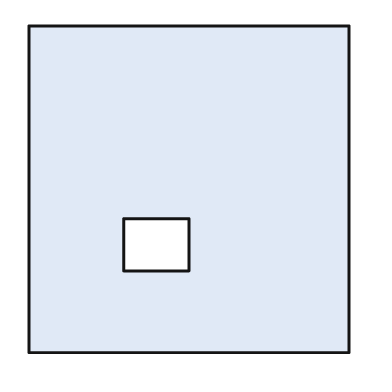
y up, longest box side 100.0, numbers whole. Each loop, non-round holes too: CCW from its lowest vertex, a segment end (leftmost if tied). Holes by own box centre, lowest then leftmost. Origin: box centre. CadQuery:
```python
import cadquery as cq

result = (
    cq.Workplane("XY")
    .moveTo(-49.0, -50.0)
    .lineTo(49.0, -50.0)
    .lineTo(49.0, 50.0)
    .lineTo(-49.0, 50.0)
    .close()
    .moveTo(-20.0, -25.0)
    .lineTo(0.0, -25.0)
    .lineTo(0.0, -9.0)
    .lineTo(-20.0, -9.0)
    .close()
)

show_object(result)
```